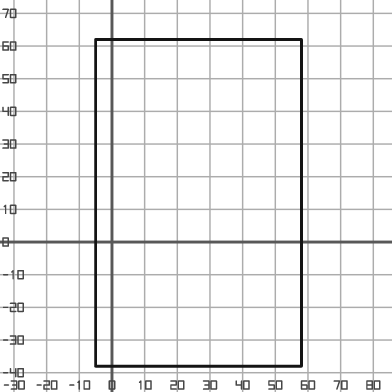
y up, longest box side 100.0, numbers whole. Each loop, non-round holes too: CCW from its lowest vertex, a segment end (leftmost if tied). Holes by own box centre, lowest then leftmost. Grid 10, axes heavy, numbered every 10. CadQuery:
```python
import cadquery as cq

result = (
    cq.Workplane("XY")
    .moveTo(-5.0, -38.0)
    .lineTo(58.0, -38.0)
    .lineTo(58.0, 62.0)
    .lineTo(-5.0, 62.0)
    .close()
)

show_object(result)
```